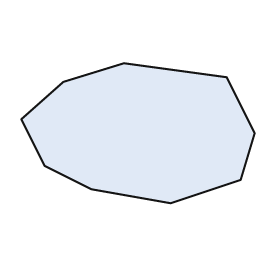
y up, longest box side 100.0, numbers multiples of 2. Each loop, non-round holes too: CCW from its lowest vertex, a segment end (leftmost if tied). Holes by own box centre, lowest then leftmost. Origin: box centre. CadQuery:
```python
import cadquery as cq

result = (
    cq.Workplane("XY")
    .moveTo(14.0, -30.0)
    .lineTo(44.0, -20.0)
    .lineTo(50.0, 0.0)
    .lineTo(38.0, 24.0)
    .lineTo(-6.0, 30.0)
    .lineTo(-32.0, 22.0)
    .lineTo(-50.0, 6.0)
    .lineTo(-40.0, -14.0)
    .lineTo(-20.0, -24.0)
    .close()
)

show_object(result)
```